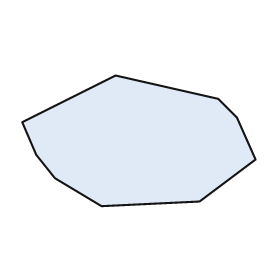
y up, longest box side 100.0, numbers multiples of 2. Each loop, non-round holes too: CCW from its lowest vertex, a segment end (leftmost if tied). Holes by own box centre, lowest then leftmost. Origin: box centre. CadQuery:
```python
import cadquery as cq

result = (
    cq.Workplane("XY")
    .moveTo(-16.0, -28.0)
    .lineTo(26.0, -26.0)
    .lineTo(50.0, -8.0)
    .lineTo(42.0, 10.0)
    .lineTo(34.0, 18.0)
    .lineTo(-10.0, 28.0)
    .lineTo(-50.0, 8.0)
    .lineTo(-44.0, -6.0)
    .lineTo(-36.0, -16.0)
    .close()
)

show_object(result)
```